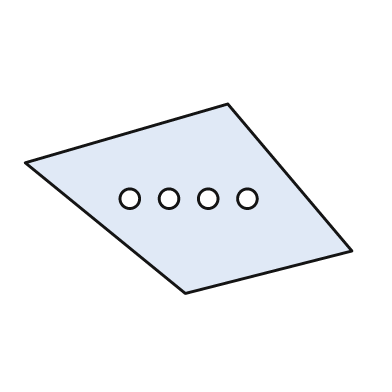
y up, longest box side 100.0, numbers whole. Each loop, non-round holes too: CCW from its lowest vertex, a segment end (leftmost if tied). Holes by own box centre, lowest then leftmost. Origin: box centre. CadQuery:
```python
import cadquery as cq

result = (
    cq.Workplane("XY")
    .moveTo(-1.0, -29.0)
    .lineTo(50.0, -16.0)
    .lineTo(12.0, 29.0)
    .lineTo(-50.0, 11.0)
    .close()
    .moveTo(-18.0, 0.0)
    .circle(3.0)
    .moveTo(-6.0, 0.0)
    .circle(3.0)
    .moveTo(6.0, 0.0)
    .circle(3.0)
    .moveTo(18.0, 0.0)
    .circle(3.0)
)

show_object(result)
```